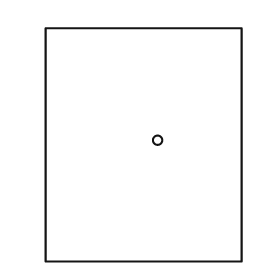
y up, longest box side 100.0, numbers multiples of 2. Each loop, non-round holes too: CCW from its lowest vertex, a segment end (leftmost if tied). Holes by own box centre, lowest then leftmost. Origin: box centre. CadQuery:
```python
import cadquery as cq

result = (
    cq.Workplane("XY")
    .moveTo(-42.0, -50.0)
    .lineTo(42.0, -50.0)
    .lineTo(42.0, 50.0)
    .lineTo(-42.0, 50.0)
    .close()
    .moveTo(6.0, 2.0)
    .circle(2.0)
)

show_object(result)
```